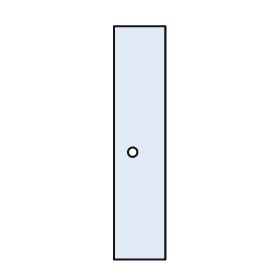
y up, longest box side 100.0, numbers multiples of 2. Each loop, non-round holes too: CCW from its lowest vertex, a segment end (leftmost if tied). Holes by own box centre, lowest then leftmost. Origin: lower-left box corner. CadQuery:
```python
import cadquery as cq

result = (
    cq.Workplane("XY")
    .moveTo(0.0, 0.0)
    .lineTo(22.0, 0.0)
    .lineTo(22.0, 100.0)
    .lineTo(0.0, 100.0)
    .close()
    .moveTo(8.0, 46.0)
    .circle(2.0)
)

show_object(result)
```